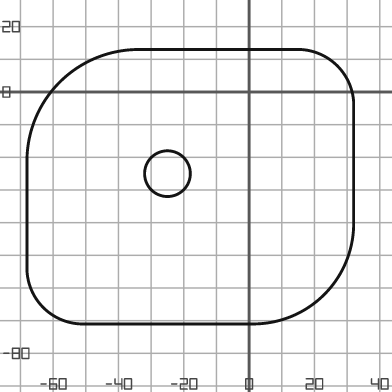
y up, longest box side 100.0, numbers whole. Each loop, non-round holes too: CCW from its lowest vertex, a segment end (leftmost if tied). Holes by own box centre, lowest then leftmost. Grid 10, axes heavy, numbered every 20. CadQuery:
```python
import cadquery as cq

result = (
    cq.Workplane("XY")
    .moveTo(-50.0, -71.0)
    .lineTo(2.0, -71.0)
    .threePointArc((23.0, -62.0), (32.0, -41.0))
    .lineTo(32.0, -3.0)
    .threePointArc((27.0, 8.0), (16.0, 13.0))
    .lineTo(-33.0, 13.0)
    .threePointArc((-58.0, 3.0), (-68.0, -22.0))
    .lineTo(-68.0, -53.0)
    .threePointArc((-63.0, -66.0), (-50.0, -71.0))
    .close()
    .moveTo(-25.0, -25.0)
    .circle(7.0)
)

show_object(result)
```